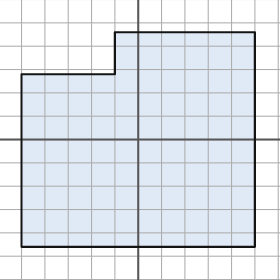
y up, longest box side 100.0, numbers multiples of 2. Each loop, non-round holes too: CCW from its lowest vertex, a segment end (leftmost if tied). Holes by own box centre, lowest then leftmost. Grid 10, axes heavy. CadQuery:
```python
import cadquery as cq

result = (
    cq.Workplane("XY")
    .moveTo(-50.0, -46.0)
    .lineTo(50.0, -46.0)
    .lineTo(50.0, 46.0)
    .lineTo(-10.0, 46.0)
    .lineTo(-10.0, 28.0)
    .lineTo(-50.0, 28.0)
    .close()
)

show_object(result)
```